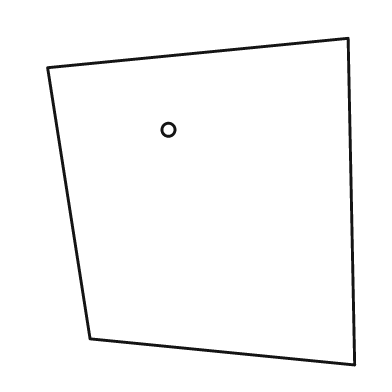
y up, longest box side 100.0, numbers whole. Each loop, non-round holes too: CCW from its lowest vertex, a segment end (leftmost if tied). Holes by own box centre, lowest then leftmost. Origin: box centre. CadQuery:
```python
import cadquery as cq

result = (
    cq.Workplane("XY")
    .moveTo(47.0, -50.0)
    .lineTo(45.0, 50.0)
    .lineTo(-47.0, 41.0)
    .lineTo(-34.0, -42.0)
    .close()
    .moveTo(-10.0, 22.0)
    .circle(2.0)
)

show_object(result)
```